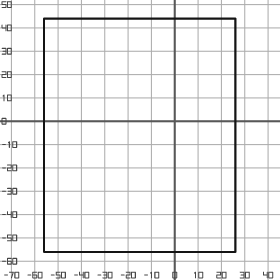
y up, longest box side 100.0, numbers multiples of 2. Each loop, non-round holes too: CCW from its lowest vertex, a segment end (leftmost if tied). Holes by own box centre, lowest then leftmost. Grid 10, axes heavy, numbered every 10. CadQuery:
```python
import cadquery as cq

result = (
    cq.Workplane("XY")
    .moveTo(-56.0, -56.0)
    .lineTo(26.0, -56.0)
    .lineTo(26.0, 44.0)
    .lineTo(-56.0, 44.0)
    .close()
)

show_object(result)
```